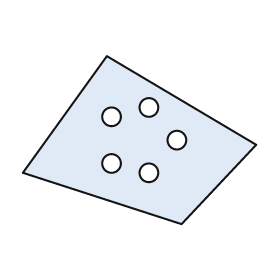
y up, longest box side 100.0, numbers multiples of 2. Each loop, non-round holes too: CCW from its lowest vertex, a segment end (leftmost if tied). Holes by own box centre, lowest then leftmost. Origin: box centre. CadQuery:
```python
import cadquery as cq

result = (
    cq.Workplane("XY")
    .moveTo(18.0, -36.0)
    .lineTo(50.0, -2.0)
    .lineTo(-14.0, 36.0)
    .lineTo(-50.0, -14.0)
    .close()
    .moveTo(4.0, -14.0)
    .circle(4.0)
    .moveTo(-12.0, -10.0)
    .circle(4.0)
    .moveTo(16.0, 0.0)
    .circle(4.0)
    .moveTo(-12.0, 10.0)
    .circle(4.0)
    .moveTo(4.0, 14.0)
    .circle(4.0)
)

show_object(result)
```